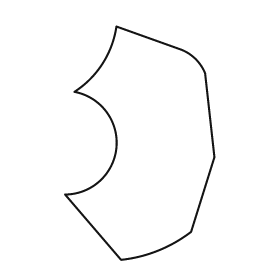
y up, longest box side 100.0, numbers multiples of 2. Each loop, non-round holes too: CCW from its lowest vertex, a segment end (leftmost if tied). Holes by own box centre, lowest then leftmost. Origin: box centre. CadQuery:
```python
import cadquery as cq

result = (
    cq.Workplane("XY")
    .moveTo(-8.0, -50.0)
    .threePointArc((8.0, -46.0), (22.0, -38.0))
    .lineTo(32.0, -6.0)
    .lineTo(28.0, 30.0)
    .threePointArc((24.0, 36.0), (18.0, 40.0))
    .lineTo(-10.0, 50.0)
    .threePointArc((-16.0, 34.0), (-28.0, 22.0))
    .threePointArc((-10.0, -2.0), (-32.0, -22.0))
    .close()
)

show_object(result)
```